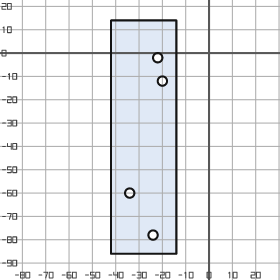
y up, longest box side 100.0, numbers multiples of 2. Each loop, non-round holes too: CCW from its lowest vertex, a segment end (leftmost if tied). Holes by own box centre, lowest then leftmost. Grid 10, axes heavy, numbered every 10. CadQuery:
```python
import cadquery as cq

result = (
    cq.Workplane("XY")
    .moveTo(-42.0, -86.0)
    .lineTo(-14.0, -86.0)
    .lineTo(-14.0, 14.0)
    .lineTo(-42.0, 14.0)
    .close()
    .moveTo(-24.0, -78.0)
    .circle(2.0)
    .moveTo(-34.0, -60.0)
    .circle(2.0)
    .moveTo(-20.0, -12.0)
    .circle(2.0)
    .moveTo(-22.0, -2.0)
    .circle(2.0)
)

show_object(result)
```